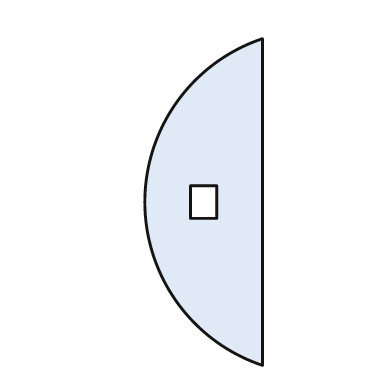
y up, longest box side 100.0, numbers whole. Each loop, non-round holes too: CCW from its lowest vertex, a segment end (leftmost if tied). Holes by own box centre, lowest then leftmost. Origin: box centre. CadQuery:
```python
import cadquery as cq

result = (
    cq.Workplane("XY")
    .moveTo(18.0, -50.0)
    .lineTo(18.0, 50.0)
    .threePointArc((-18.0, 0.0), (18.0, -50.0))
    .close()
    .moveTo(-4.0, -5.0)
    .lineTo(4.0, -5.0)
    .lineTo(4.0, 5.0)
    .lineTo(-4.0, 5.0)
    .close()
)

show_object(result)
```